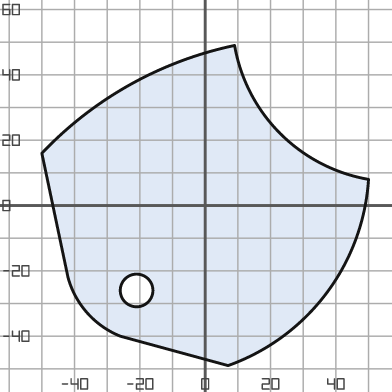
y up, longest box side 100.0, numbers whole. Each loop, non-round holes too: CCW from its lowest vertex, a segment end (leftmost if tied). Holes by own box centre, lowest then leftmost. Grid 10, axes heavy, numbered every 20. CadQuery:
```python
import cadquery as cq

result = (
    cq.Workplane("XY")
    .moveTo(7.0, -49.0)
    .threePointArc((37.0, -27.0), (50.0, 8.0))
    .threePointArc((23.0, 22.0), (9.0, 49.0))
    .threePointArc((-23.0, 37.0), (-50.0, 16.0))
    .lineTo(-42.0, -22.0)
    .threePointArc((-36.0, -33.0), (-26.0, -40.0))
    .close()
    .moveTo(-21.0, -26.0)
    .circle(5.0)
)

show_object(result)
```